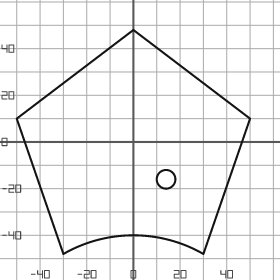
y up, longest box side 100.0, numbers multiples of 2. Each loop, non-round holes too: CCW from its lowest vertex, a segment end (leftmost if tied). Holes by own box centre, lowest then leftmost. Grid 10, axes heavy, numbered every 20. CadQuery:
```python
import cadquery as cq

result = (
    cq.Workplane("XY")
    .moveTo(-30.0, -48.0)
    .threePointArc((0.0, -40.0), (30.0, -48.0))
    .lineTo(50.0, 10.0)
    .lineTo(0.0, 48.0)
    .lineTo(-50.0, 10.0)
    .close()
    .moveTo(14.0, -16.0)
    .circle(4.0)
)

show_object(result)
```